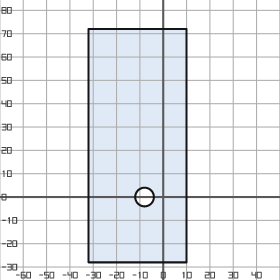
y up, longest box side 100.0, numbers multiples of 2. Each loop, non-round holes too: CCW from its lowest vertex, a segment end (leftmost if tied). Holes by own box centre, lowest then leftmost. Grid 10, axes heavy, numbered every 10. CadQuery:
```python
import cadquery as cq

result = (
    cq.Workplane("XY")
    .moveTo(-32.0, -28.0)
    .lineTo(10.0, -28.0)
    .lineTo(10.0, 72.0)
    .lineTo(-32.0, 72.0)
    .close()
    .moveTo(-8.0, 0.0)
    .circle(4.0)
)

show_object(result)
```